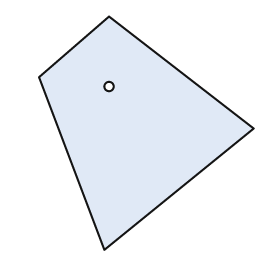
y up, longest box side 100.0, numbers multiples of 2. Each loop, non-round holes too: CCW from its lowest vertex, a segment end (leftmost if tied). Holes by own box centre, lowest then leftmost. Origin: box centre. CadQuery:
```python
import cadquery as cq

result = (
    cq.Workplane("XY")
    .moveTo(-18.0, -50.0)
    .lineTo(46.0, 2.0)
    .lineTo(-16.0, 50.0)
    .lineTo(-46.0, 24.0)
    .close()
    .moveTo(-16.0, 20.0)
    .circle(2.0)
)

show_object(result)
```